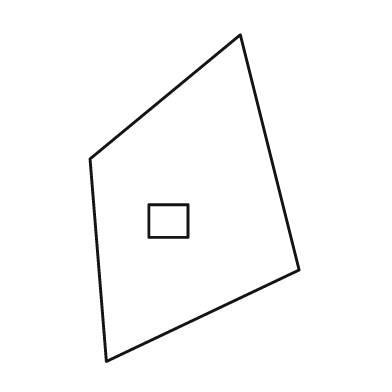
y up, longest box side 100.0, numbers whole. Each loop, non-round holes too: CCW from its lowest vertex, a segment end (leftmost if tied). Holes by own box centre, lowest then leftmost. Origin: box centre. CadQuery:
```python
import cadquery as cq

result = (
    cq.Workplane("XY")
    .moveTo(-27.0, -50.0)
    .lineTo(32.0, -22.0)
    .lineTo(14.0, 50.0)
    .lineTo(-32.0, 12.0)
    .close()
    .moveTo(-14.0, -12.0)
    .lineTo(-2.0, -12.0)
    .lineTo(-2.0, -2.0)
    .lineTo(-14.0, -2.0)
    .close()
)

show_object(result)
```